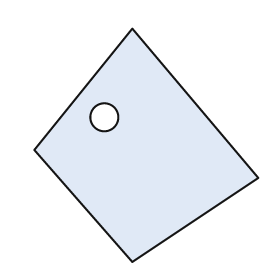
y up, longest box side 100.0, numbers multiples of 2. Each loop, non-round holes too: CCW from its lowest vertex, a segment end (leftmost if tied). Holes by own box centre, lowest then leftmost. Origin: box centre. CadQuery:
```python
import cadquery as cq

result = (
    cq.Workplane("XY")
    .moveTo(-6.0, -50.0)
    .lineTo(48.0, -14.0)
    .lineTo(-6.0, 50.0)
    .lineTo(-48.0, -2.0)
    .close()
    .moveTo(-18.0, 12.0)
    .circle(6.0)
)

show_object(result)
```